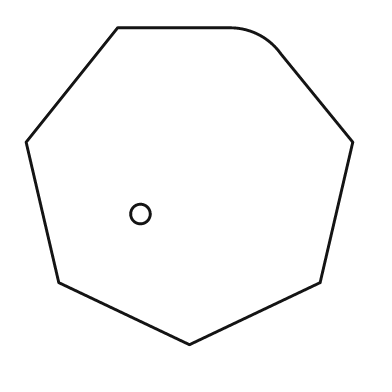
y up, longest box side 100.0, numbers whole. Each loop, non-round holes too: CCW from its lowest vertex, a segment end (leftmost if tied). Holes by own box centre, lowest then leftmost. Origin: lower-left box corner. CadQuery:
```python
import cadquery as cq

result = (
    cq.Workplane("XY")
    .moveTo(50.0, 0.0)
    .lineTo(90.0, 19.0)
    .lineTo(100.0, 62.0)
    .lineTo(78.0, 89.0)
    .threePointArc((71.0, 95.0), (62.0, 97.0))
    .lineTo(28.0, 97.0)
    .lineTo(0.0, 62.0)
    .lineTo(10.0, 19.0)
    .close()
    .moveTo(35.0, 40.0)
    .circle(3.0)
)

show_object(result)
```